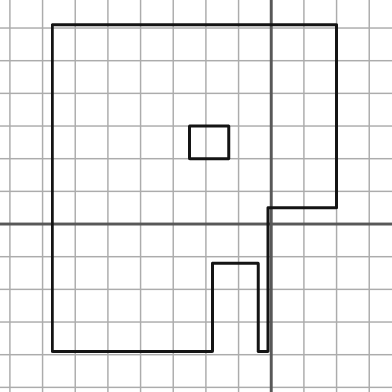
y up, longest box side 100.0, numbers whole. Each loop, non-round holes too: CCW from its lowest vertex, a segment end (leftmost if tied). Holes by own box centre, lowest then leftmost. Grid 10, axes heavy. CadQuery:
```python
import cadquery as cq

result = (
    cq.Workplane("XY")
    .moveTo(-67.0, -39.0)
    .lineTo(-18.0, -39.0)
    .lineTo(-18.0, -12.0)
    .lineTo(-4.0, -12.0)
    .lineTo(-4.0, -39.0)
    .lineTo(-1.0, -39.0)
    .lineTo(-1.0, 5.0)
    .lineTo(20.0, 5.0)
    .lineTo(20.0, 61.0)
    .lineTo(-67.0, 61.0)
    .close()
    .moveTo(-25.0, 20.0)
    .lineTo(-13.0, 20.0)
    .lineTo(-13.0, 30.0)
    .lineTo(-25.0, 30.0)
    .close()
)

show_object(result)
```